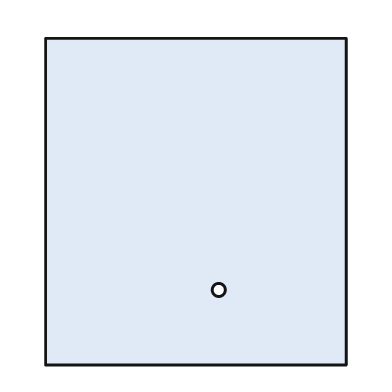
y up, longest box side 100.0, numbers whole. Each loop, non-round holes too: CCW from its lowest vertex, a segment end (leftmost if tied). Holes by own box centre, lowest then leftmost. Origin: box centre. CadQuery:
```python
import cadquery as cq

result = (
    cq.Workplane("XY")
    .moveTo(-46.0, -50.0)
    .lineTo(46.0, -50.0)
    .lineTo(46.0, 50.0)
    .lineTo(-46.0, 50.0)
    .close()
    .moveTo(7.0, -27.0)
    .circle(2.0)
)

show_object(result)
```